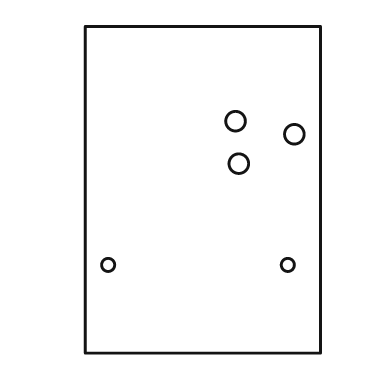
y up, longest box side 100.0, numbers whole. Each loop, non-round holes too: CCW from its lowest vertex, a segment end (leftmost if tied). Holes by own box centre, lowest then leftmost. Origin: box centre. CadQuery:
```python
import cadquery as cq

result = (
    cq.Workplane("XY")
    .moveTo(-36.0, -50.0)
    .lineTo(36.0, -50.0)
    .lineTo(36.0, 50.0)
    .lineTo(-36.0, 50.0)
    .close()
    .moveTo(-29.0, -23.0)
    .circle(2.0)
    .moveTo(26.0, -23.0)
    .circle(2.0)
    .moveTo(11.0, 8.0)
    .circle(3.0)
    .moveTo(28.0, 17.0)
    .circle(3.0)
    .moveTo(10.0, 21.0)
    .circle(3.0)
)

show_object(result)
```